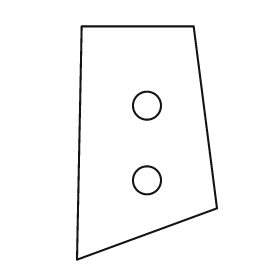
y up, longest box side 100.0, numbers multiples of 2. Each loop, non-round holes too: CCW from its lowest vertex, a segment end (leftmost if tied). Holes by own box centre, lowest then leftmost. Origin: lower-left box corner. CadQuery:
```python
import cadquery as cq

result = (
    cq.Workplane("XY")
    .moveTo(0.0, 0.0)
    .lineTo(60.0, 22.0)
    .lineTo(50.0, 100.0)
    .lineTo(2.0, 100.0)
    .close()
    .moveTo(30.0, 34.0)
    .circle(6.0)
    .moveTo(30.0, 66.0)
    .circle(6.0)
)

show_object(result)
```